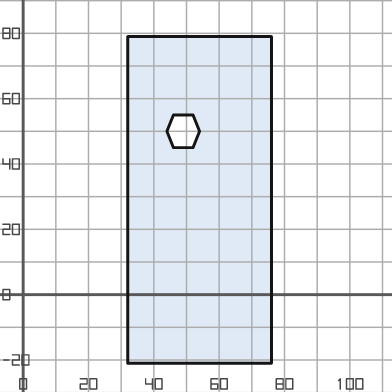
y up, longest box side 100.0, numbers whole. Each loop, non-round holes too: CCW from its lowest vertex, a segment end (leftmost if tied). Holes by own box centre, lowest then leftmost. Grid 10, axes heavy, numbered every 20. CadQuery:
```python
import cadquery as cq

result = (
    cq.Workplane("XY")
    .moveTo(32.0, -21.0)
    .lineTo(76.0, -21.0)
    .lineTo(76.0, 79.0)
    .lineTo(32.0, 79.0)
    .close()
    .moveTo(46.0, 45.0)
    .lineTo(52.0, 45.0)
    .lineTo(54.0, 50.0)
    .lineTo(52.0, 55.0)
    .lineTo(46.0, 55.0)
    .lineTo(44.0, 50.0)
    .close()
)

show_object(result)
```